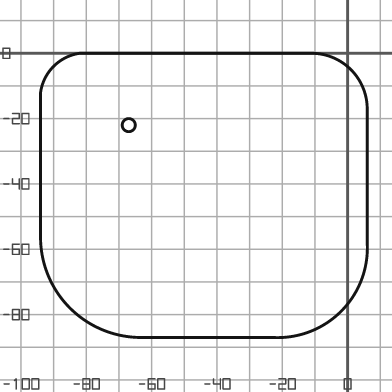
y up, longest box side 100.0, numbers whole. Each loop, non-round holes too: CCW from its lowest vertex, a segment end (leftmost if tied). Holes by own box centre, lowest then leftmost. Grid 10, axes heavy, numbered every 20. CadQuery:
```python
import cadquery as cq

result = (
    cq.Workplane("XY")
    .moveTo(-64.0, -87.0)
    .lineTo(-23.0, -87.0)
    .threePointArc((-2.0, -79.0), (6.0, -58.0))
    .lineTo(6.0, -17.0)
    .threePointArc((1.0, -5.0), (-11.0, 0.0))
    .lineTo(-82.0, 0.0)
    .threePointArc((-90.0, -4.0), (-94.0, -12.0))
    .lineTo(-94.0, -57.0)
    .threePointArc((-85.0, -78.0), (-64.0, -87.0))
    .close()
    .moveTo(-67.0, -22.0)
    .circle(2.0)
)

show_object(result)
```